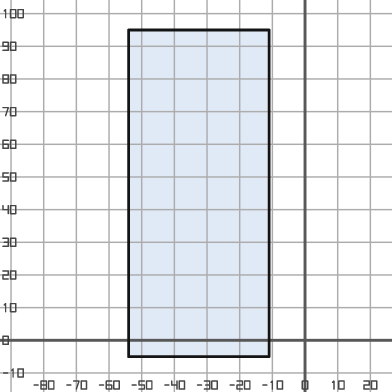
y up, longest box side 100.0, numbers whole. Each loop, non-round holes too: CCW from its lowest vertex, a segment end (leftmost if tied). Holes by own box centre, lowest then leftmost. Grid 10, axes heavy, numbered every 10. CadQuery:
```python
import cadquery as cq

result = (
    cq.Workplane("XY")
    .moveTo(-54.0, -5.0)
    .lineTo(-11.0, -5.0)
    .lineTo(-11.0, 95.0)
    .lineTo(-54.0, 95.0)
    .close()
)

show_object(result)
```